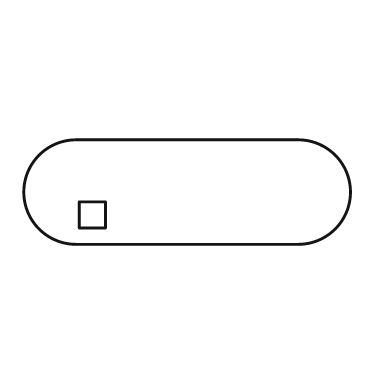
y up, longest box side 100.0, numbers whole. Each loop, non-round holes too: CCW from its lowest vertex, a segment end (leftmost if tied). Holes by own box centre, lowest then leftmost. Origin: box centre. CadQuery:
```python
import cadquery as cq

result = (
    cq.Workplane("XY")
    .moveTo(-34.0, -16.0)
    .lineTo(34.0, -16.0)
    .threePointArc((50.0, 0.0), (34.0, 16.0))
    .lineTo(-34.0, 16.0)
    .threePointArc((-50.0, 0.0), (-34.0, -16.0))
    .close()
    .moveTo(-33.0, -11.0)
    .lineTo(-25.0, -11.0)
    .lineTo(-25.0, -3.0)
    .lineTo(-33.0, -3.0)
    .close()
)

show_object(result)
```